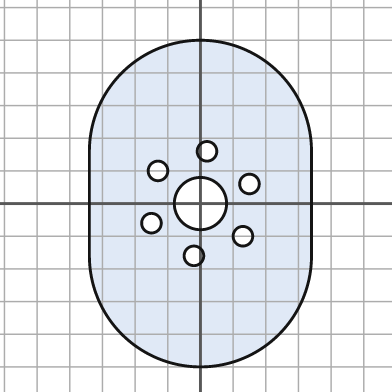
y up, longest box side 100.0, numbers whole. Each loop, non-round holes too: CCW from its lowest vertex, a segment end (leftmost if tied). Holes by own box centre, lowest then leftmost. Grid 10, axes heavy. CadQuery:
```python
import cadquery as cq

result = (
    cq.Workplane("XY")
    .moveTo(-34.0, -16.0)
    .threePointArc((0.0, -50.0), (34.0, -16.0))
    .lineTo(34.0, 16.0)
    .threePointArc((0.0, 50.0), (-34.0, 16.0))
    .close()
    .moveTo(-2.0, -16.0)
    .circle(3.0)
    .moveTo(13.0, -10.0)
    .circle(3.0)
    .moveTo(-15.0, -6.0)
    .circle(3.0)
    .moveTo(0.0, 0.0)
    .circle(8.0)
    .moveTo(15.0, 6.0)
    .circle(3.0)
    .moveTo(-13.0, 10.0)
    .circle(3.0)
    .moveTo(2.0, 16.0)
    .circle(3.0)
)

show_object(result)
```